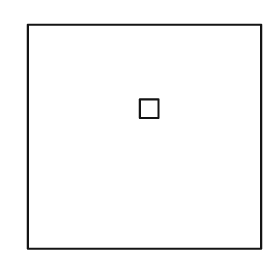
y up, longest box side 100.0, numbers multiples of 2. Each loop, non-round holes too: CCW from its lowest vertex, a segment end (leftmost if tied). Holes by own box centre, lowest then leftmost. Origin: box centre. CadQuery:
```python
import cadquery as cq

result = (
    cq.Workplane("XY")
    .moveTo(-50.0, -48.0)
    .lineTo(50.0, -48.0)
    .lineTo(50.0, 48.0)
    .lineTo(-50.0, 48.0)
    .close()
    .moveTo(-2.0, 8.0)
    .lineTo(6.0, 8.0)
    .lineTo(6.0, 16.0)
    .lineTo(-2.0, 16.0)
    .close()
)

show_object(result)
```